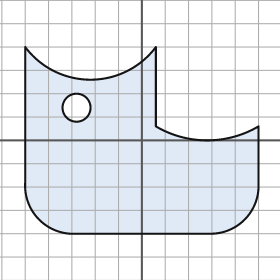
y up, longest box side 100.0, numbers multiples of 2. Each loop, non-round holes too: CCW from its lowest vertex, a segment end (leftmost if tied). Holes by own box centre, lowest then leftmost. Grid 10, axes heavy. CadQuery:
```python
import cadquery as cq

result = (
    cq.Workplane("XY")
    .moveTo(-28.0, -40.0)
    .lineTo(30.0, -40.0)
    .threePointArc((44.0, -34.0), (50.0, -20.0))
    .lineTo(50.0, 6.0)
    .threePointArc((28.0, 0.0), (6.0, 6.0))
    .lineTo(6.0, 40.0)
    .threePointArc((-22.0, 26.0), (-50.0, 40.0))
    .lineTo(-50.0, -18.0)
    .threePointArc((-44.0, -34.0), (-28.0, -40.0))
    .close()
    .moveTo(-28.0, 14.0)
    .circle(6.0)
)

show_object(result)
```